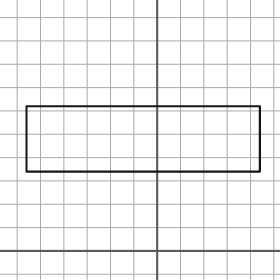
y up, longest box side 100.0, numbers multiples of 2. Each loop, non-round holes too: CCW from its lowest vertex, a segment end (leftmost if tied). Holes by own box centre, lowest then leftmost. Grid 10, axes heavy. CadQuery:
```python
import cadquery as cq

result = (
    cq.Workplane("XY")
    .moveTo(-56.0, 34.0)
    .lineTo(44.0, 34.0)
    .lineTo(44.0, 62.0)
    .lineTo(-56.0, 62.0)
    .close()
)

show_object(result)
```